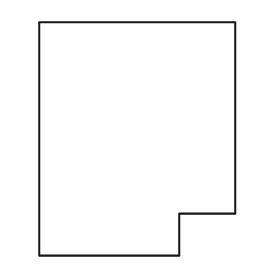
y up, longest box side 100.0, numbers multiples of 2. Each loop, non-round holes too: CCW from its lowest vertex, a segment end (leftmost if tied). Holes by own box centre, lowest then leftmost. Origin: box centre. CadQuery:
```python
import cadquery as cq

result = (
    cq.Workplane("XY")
    .moveTo(-42.0, -50.0)
    .lineTo(18.0, -50.0)
    .lineTo(18.0, -32.0)
    .lineTo(42.0, -32.0)
    .lineTo(42.0, 50.0)
    .lineTo(-42.0, 50.0)
    .close()
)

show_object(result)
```